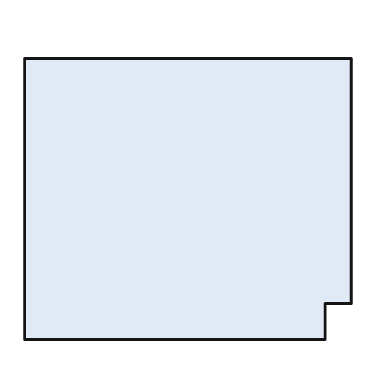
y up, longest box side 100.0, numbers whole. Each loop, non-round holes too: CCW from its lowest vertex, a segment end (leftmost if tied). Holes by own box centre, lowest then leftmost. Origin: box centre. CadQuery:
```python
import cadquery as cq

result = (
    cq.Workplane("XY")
    .moveTo(-50.0, -43.0)
    .lineTo(42.0, -43.0)
    .lineTo(42.0, -32.0)
    .lineTo(50.0, -32.0)
    .lineTo(50.0, 43.0)
    .lineTo(-50.0, 43.0)
    .close()
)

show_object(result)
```